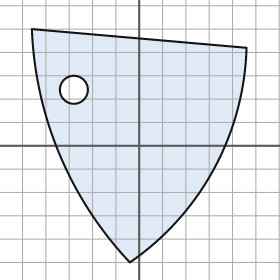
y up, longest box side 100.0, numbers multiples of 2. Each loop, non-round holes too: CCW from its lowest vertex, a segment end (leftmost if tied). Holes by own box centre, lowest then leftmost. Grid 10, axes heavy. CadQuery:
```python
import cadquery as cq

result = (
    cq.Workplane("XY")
    .moveTo(-4.0, -50.0)
    .threePointArc((32.0, -10.0), (46.0, 42.0))
    .lineTo(-46.0, 50.0)
    .threePointArc((-34.0, -4.0), (-4.0, -50.0))
    .close()
    .moveTo(-28.0, 24.0)
    .circle(6.0)
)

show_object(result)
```